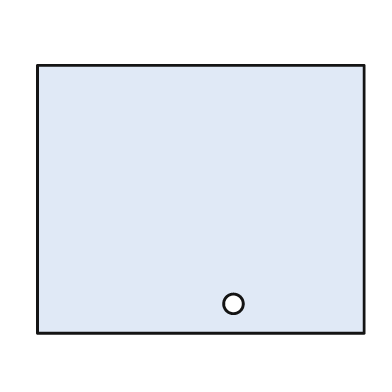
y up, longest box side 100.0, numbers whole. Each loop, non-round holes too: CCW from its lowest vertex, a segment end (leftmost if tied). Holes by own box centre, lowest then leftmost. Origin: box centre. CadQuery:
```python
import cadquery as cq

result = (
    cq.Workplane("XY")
    .moveTo(-50.0, -41.0)
    .lineTo(50.0, -41.0)
    .lineTo(50.0, 41.0)
    .lineTo(-50.0, 41.0)
    .close()
    .moveTo(10.0, -32.0)
    .circle(3.0)
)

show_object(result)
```